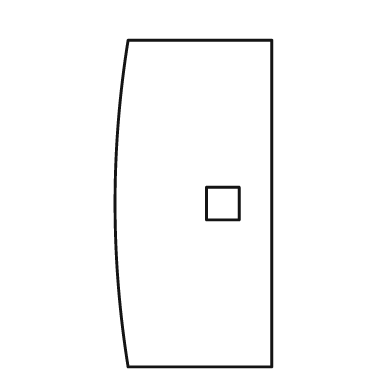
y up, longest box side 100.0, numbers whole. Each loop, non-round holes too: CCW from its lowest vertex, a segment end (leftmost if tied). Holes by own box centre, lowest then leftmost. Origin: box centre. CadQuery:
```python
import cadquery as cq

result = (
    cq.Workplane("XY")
    .moveTo(-20.0, -50.0)
    .lineTo(24.0, -50.0)
    .lineTo(24.0, 50.0)
    .lineTo(-20.0, 50.0)
    .threePointArc((-24.0, 0.0), (-20.0, -50.0))
    .close()
    .moveTo(4.0, -5.0)
    .lineTo(14.0, -5.0)
    .lineTo(14.0, 5.0)
    .lineTo(4.0, 5.0)
    .close()
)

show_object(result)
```